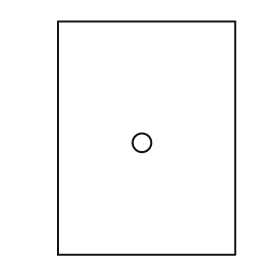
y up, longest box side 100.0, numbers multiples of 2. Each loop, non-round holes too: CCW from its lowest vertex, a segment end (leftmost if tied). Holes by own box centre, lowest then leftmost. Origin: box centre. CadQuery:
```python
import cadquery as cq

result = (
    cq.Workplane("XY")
    .moveTo(-38.0, -50.0)
    .lineTo(38.0, -50.0)
    .lineTo(38.0, 50.0)
    .lineTo(-38.0, 50.0)
    .close()
    .moveTo(-2.0, -2.0)
    .circle(4.0)
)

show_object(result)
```